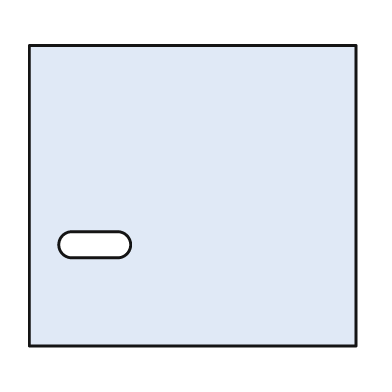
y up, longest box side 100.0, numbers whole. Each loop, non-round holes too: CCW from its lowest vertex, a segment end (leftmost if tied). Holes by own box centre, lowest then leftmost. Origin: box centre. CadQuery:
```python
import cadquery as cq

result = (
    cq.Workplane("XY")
    .moveTo(-50.0, -46.0)
    .lineTo(50.0, -46.0)
    .lineTo(50.0, 46.0)
    .lineTo(-50.0, 46.0)
    .close()
    .moveTo(-37.0, -19.0)
    .lineTo(-23.0, -19.0)
    .threePointArc((-19.0, -15.0), (-23.0, -11.0))
    .lineTo(-37.0, -11.0)
    .threePointArc((-41.0, -15.0), (-37.0, -19.0))
    .close()
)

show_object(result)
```